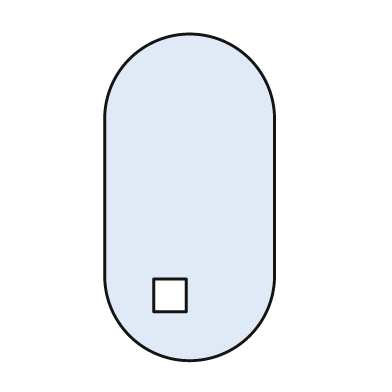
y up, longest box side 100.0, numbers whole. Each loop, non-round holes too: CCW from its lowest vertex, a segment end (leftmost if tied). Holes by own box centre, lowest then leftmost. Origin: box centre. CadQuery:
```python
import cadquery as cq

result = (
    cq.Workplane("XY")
    .moveTo(-26.0, -24.0)
    .threePointArc((0.0, -50.0), (26.0, -24.0))
    .lineTo(26.0, 24.0)
    .threePointArc((0.0, 50.0), (-26.0, 24.0))
    .close()
    .moveTo(-11.0, -35.0)
    .lineTo(-1.0, -35.0)
    .lineTo(-1.0, -25.0)
    .lineTo(-11.0, -25.0)
    .close()
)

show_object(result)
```